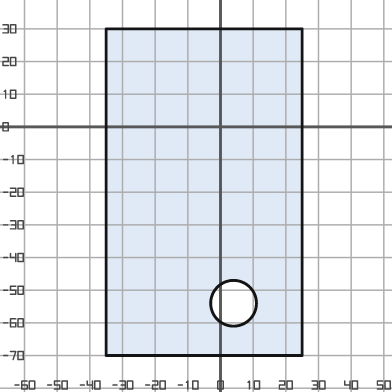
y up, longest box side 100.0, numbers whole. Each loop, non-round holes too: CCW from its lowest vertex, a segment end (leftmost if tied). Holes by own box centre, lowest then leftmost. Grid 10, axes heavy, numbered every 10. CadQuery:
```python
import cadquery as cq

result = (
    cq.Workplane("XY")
    .moveTo(-35.0, -70.0)
    .lineTo(25.0, -70.0)
    .lineTo(25.0, 30.0)
    .lineTo(-35.0, 30.0)
    .close()
    .moveTo(4.0, -54.0)
    .circle(7.0)
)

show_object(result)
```